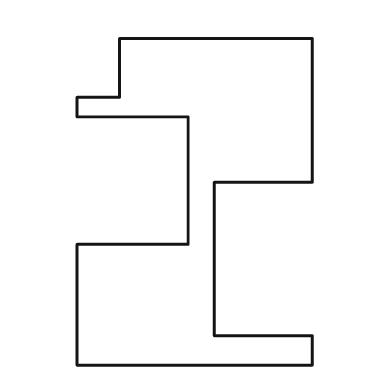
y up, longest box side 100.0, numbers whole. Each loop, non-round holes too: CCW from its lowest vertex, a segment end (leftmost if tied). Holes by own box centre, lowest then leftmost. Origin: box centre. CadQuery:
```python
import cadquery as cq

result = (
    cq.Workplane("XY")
    .moveTo(-36.0, -50.0)
    .lineTo(36.0, -50.0)
    .lineTo(36.0, -41.0)
    .lineTo(6.0, -41.0)
    .lineTo(6.0, 6.0)
    .lineTo(36.0, 6.0)
    .lineTo(36.0, 50.0)
    .lineTo(-23.0, 50.0)
    .lineTo(-23.0, 32.0)
    .lineTo(-36.0, 32.0)
    .lineTo(-36.0, 26.0)
    .lineTo(-2.0, 26.0)
    .lineTo(-2.0, -13.0)
    .lineTo(-36.0, -13.0)
    .close()
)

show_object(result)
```